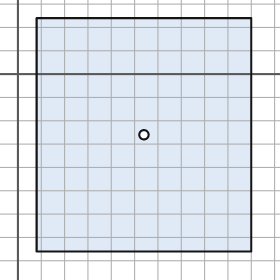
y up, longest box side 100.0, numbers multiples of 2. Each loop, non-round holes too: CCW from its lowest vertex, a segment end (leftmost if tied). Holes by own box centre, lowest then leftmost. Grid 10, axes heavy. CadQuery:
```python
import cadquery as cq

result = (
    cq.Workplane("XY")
    .moveTo(8.0, -76.0)
    .lineTo(100.0, -76.0)
    .lineTo(100.0, 24.0)
    .lineTo(8.0, 24.0)
    .close()
    .moveTo(54.0, -26.0)
    .circle(2.0)
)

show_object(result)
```